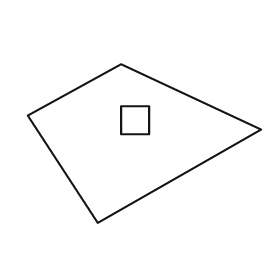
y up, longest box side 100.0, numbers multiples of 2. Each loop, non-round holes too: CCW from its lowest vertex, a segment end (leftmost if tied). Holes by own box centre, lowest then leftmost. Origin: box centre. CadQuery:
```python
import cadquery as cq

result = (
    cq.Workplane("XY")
    .moveTo(-20.0, -34.0)
    .lineTo(50.0, 6.0)
    .lineTo(-10.0, 34.0)
    .lineTo(-50.0, 12.0)
    .close()
    .moveTo(-10.0, 4.0)
    .lineTo(2.0, 4.0)
    .lineTo(2.0, 16.0)
    .lineTo(-10.0, 16.0)
    .close()
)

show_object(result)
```